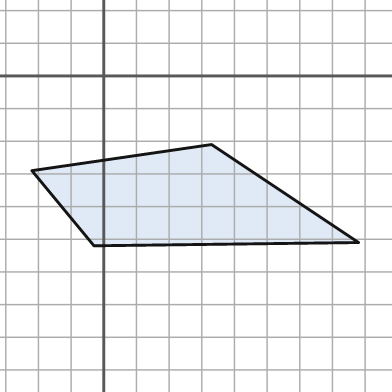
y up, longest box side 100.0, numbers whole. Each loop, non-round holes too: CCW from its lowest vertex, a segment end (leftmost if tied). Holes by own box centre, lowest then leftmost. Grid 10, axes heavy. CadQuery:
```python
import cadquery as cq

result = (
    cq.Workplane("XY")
    .moveTo(-3.0, -52.0)
    .lineTo(78.0, -51.0)
    .lineTo(33.0, -21.0)
    .lineTo(-22.0, -29.0)
    .close()
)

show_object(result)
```